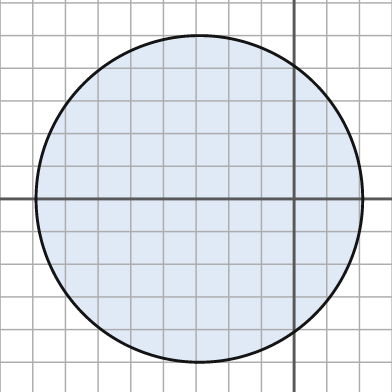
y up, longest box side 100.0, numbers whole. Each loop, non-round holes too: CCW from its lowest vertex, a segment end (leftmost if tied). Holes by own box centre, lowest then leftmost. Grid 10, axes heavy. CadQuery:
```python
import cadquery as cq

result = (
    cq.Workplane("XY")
    .moveTo(-29.0, 0.0)
    .circle(50.0)
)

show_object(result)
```